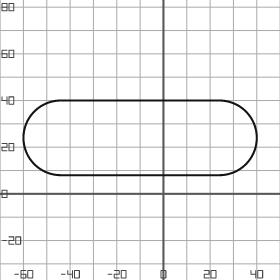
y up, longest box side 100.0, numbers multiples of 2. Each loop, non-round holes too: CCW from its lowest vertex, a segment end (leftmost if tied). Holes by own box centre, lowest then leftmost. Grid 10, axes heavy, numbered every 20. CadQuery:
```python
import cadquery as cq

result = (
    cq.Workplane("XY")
    .moveTo(-44.0, 8.0)
    .lineTo(24.0, 8.0)
    .threePointArc((40.0, 24.0), (24.0, 40.0))
    .lineTo(-44.0, 40.0)
    .threePointArc((-60.0, 24.0), (-44.0, 8.0))
    .close()
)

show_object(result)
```